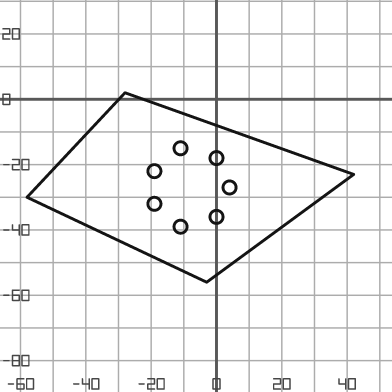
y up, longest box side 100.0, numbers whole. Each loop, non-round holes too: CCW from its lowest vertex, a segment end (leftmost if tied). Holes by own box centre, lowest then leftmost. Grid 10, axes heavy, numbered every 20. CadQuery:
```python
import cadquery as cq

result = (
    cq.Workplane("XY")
    .moveTo(-3.0, -56.0)
    .lineTo(42.0, -23.0)
    .lineTo(-28.0, 2.0)
    .lineTo(-58.0, -30.0)
    .close()
    .moveTo(-11.0, -39.0)
    .circle(2.0)
    .moveTo(0.0, -36.0)
    .circle(2.0)
    .moveTo(-19.0, -32.0)
    .circle(2.0)
    .moveTo(4.0, -27.0)
    .circle(2.0)
    .moveTo(-19.0, -22.0)
    .circle(2.0)
    .moveTo(0.0, -18.0)
    .circle(2.0)
    .moveTo(-11.0, -15.0)
    .circle(2.0)
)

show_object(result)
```